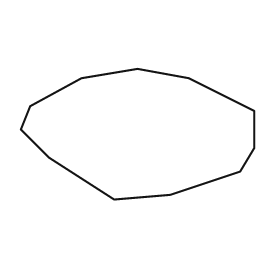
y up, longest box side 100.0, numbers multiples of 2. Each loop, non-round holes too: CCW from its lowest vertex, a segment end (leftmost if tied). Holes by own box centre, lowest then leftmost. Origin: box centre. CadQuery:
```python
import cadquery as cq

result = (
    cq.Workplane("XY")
    .moveTo(-10.0, -28.0)
    .lineTo(14.0, -26.0)
    .lineTo(44.0, -16.0)
    .lineTo(50.0, -6.0)
    .lineTo(50.0, 10.0)
    .lineTo(22.0, 24.0)
    .lineTo(0.0, 28.0)
    .lineTo(-24.0, 24.0)
    .lineTo(-46.0, 12.0)
    .lineTo(-50.0, 2.0)
    .lineTo(-38.0, -10.0)
    .close()
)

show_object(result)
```